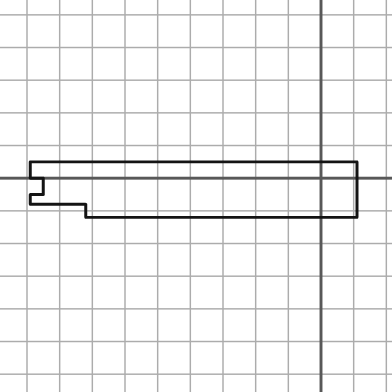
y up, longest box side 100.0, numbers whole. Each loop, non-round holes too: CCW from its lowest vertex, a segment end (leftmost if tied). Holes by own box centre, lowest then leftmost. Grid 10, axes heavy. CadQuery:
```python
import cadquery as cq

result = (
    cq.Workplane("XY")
    .moveTo(-72.0, -12.0)
    .lineTo(11.0, -12.0)
    .lineTo(11.0, 5.0)
    .lineTo(-89.0, 5.0)
    .lineTo(-89.0, 0.0)
    .lineTo(-85.0, 0.0)
    .lineTo(-85.0, -5.0)
    .lineTo(-89.0, -5.0)
    .lineTo(-89.0, -8.0)
    .lineTo(-72.0, -8.0)
    .close()
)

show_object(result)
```